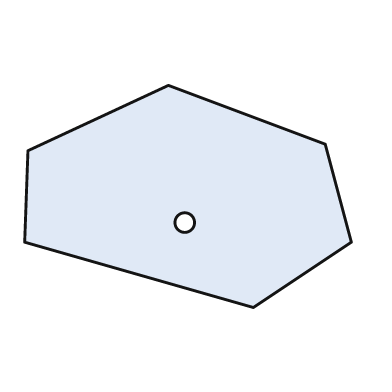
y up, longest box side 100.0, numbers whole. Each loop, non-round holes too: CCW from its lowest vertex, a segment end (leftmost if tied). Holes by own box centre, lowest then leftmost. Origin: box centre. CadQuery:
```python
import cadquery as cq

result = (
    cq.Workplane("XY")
    .moveTo(20.0, -34.0)
    .lineTo(50.0, -14.0)
    .lineTo(42.0, 16.0)
    .lineTo(-6.0, 34.0)
    .lineTo(-49.0, 14.0)
    .lineTo(-50.0, -14.0)
    .close()
    .moveTo(-1.0, -8.0)
    .circle(3.0)
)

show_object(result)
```